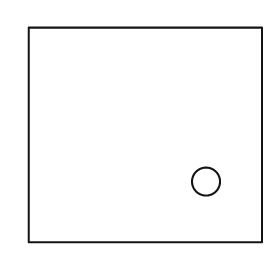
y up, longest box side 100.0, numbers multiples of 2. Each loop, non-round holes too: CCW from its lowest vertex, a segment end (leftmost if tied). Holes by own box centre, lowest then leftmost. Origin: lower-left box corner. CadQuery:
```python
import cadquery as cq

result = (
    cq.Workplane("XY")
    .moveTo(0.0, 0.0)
    .lineTo(100.0, 0.0)
    .lineTo(100.0, 92.0)
    .lineTo(0.0, 92.0)
    .close()
    .moveTo(76.0, 26.0)
    .circle(6.0)
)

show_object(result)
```